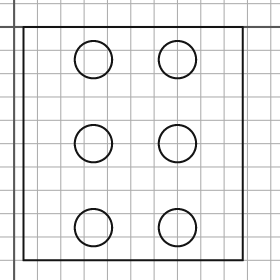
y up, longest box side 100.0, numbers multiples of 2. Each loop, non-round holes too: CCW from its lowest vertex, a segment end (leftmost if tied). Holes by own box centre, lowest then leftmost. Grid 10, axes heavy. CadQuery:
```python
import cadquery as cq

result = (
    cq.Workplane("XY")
    .moveTo(4.0, -100.0)
    .lineTo(98.0, -100.0)
    .lineTo(98.0, 0.0)
    .lineTo(4.0, 0.0)
    .close()
    .moveTo(34.0, -86.0)
    .circle(8.0)
    .moveTo(70.0, -86.0)
    .circle(8.0)
    .moveTo(34.0, -50.0)
    .circle(8.0)
    .moveTo(70.0, -50.0)
    .circle(8.0)
    .moveTo(34.0, -14.0)
    .circle(8.0)
    .moveTo(70.0, -14.0)
    .circle(8.0)
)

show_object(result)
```